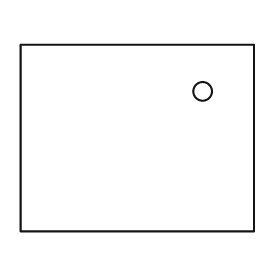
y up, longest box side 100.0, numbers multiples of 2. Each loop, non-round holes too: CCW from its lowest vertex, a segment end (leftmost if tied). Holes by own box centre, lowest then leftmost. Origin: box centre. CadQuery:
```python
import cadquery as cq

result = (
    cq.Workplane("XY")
    .moveTo(-50.0, -40.0)
    .lineTo(50.0, -40.0)
    .lineTo(50.0, 40.0)
    .lineTo(-50.0, 40.0)
    .close()
    .moveTo(28.0, 20.0)
    .circle(4.0)
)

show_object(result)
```